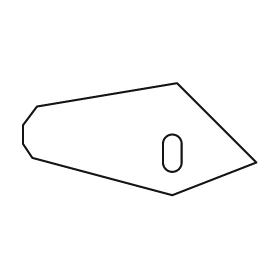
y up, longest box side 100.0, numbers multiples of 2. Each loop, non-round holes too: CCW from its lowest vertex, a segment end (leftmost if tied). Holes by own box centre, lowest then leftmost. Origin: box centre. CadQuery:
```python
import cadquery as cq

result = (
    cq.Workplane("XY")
    .moveTo(14.0, -24.0)
    .lineTo(50.0, -10.0)
    .lineTo(16.0, 24.0)
    .lineTo(-44.0, 14.0)
    .lineTo(-50.0, 6.0)
    .lineTo(-50.0, -2.0)
    .lineTo(-46.0, -8.0)
    .close()
    .moveTo(10.0, -10.0)
    .threePointArc((14.0, -14.0), (18.0, -10.0))
    .lineTo(18.0, -2.0)
    .threePointArc((14.0, 2.0), (10.0, -2.0))
    .close()
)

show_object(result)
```